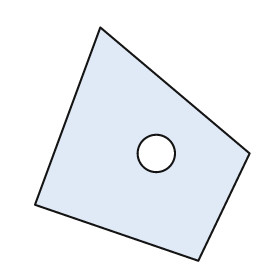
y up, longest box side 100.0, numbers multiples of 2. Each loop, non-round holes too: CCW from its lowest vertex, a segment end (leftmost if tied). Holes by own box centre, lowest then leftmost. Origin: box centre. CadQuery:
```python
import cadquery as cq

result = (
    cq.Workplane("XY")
    .moveTo(24.0, -50.0)
    .lineTo(46.0, -4.0)
    .lineTo(-18.0, 50.0)
    .lineTo(-46.0, -26.0)
    .close()
    .moveTo(6.0, -4.0)
    .circle(8.0)
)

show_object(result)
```